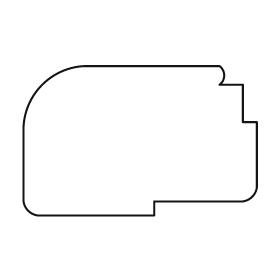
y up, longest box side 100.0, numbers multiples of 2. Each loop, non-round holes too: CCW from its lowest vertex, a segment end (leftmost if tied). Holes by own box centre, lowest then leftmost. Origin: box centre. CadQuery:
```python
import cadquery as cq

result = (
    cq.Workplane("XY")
    .moveTo(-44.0, -32.0)
    .lineTo(6.0, -32.0)
    .lineTo(6.0, -26.0)
    .lineTo(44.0, -26.0)
    .threePointArc((48.0, -24.0), (50.0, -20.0))
    .lineTo(50.0, 8.0)
    .lineTo(44.0, 8.0)
    .lineTo(44.0, 24.0)
    .lineTo(34.0, 24.0)
    .threePointArc((36.0, 28.0), (34.0, 32.0))
    .lineTo(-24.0, 32.0)
    .threePointArc((-42.0, 24.0), (-50.0, 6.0))
    .lineTo(-50.0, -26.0)
    .threePointArc((-48.0, -30.0), (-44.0, -32.0))
    .close()
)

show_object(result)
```